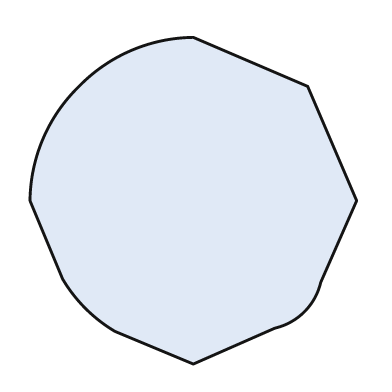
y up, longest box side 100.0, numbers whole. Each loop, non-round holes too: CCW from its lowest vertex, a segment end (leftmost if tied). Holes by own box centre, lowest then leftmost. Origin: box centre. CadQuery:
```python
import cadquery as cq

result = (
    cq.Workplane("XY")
    .moveTo(0.0, -50.0)
    .lineTo(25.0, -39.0)
    .threePointArc((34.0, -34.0), (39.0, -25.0))
    .lineTo(50.0, 0.0)
    .lineTo(35.0, 35.0)
    .lineTo(0.0, 50.0)
    .threePointArc((-19.0, 46.0), (-35.0, 35.0))
    .threePointArc((-46.0, 19.0), (-50.0, 0.0))
    .lineTo(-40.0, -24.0)
    .threePointArc((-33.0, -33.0), (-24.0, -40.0))
    .close()
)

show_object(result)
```